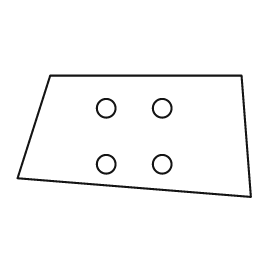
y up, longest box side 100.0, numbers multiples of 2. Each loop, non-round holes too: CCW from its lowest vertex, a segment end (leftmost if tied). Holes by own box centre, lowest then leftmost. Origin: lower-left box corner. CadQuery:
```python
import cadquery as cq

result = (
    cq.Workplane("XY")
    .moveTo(100.0, 0.0)
    .lineTo(96.0, 52.0)
    .lineTo(14.0, 52.0)
    .lineTo(0.0, 8.0)
    .close()
    .moveTo(38.0, 14.0)
    .circle(4.0)
    .moveTo(62.0, 14.0)
    .circle(4.0)
    .moveTo(38.0, 38.0)
    .circle(4.0)
    .moveTo(62.0, 38.0)
    .circle(4.0)
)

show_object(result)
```